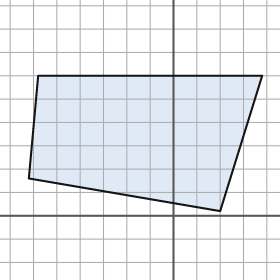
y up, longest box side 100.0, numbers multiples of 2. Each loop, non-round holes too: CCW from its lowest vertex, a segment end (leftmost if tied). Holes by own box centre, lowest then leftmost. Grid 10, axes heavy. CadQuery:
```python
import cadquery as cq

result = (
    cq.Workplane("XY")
    .moveTo(20.0, 2.0)
    .lineTo(38.0, 60.0)
    .lineTo(-58.0, 60.0)
    .lineTo(-62.0, 16.0)
    .close()
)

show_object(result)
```